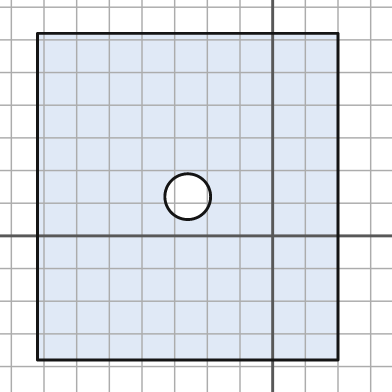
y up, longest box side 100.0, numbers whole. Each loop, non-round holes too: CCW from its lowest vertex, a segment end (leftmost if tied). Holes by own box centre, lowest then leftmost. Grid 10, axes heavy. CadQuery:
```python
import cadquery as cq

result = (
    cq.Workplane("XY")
    .moveTo(-72.0, -38.0)
    .lineTo(20.0, -38.0)
    .lineTo(20.0, 62.0)
    .lineTo(-72.0, 62.0)
    .close()
    .moveTo(-26.0, 12.0)
    .circle(7.0)
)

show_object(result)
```